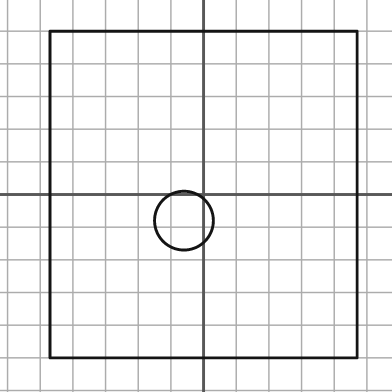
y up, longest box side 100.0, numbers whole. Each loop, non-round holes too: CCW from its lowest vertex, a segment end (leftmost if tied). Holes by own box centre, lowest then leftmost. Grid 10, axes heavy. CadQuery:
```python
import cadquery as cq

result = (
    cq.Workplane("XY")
    .moveTo(-47.0, -50.0)
    .lineTo(47.0, -50.0)
    .lineTo(47.0, 50.0)
    .lineTo(-47.0, 50.0)
    .close()
    .moveTo(-6.0, -8.0)
    .circle(9.0)
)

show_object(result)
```